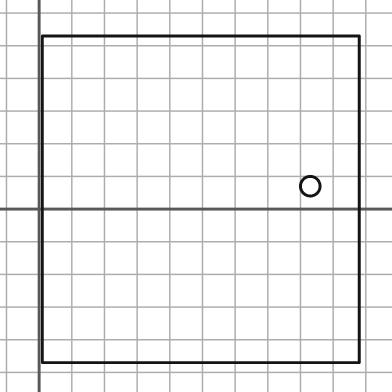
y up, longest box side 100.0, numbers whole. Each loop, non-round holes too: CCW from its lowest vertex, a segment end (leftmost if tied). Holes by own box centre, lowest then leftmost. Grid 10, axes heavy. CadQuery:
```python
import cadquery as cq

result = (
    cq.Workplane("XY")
    .moveTo(1.0, -47.0)
    .lineTo(98.0, -47.0)
    .lineTo(98.0, 53.0)
    .lineTo(1.0, 53.0)
    .close()
    .moveTo(83.0, 7.0)
    .circle(3.0)
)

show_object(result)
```